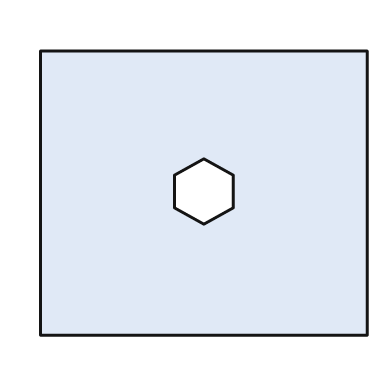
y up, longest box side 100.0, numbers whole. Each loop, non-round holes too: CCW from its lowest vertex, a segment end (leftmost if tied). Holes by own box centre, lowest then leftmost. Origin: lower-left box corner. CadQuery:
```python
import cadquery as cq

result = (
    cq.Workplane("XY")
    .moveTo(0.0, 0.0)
    .lineTo(100.0, 0.0)
    .lineTo(100.0, 87.0)
    .lineTo(0.0, 87.0)
    .close()
    .moveTo(50.0, 34.0)
    .lineTo(59.0, 39.0)
    .lineTo(59.0, 49.0)
    .lineTo(50.0, 54.0)
    .lineTo(41.0, 49.0)
    .lineTo(41.0, 39.0)
    .close()
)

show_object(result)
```